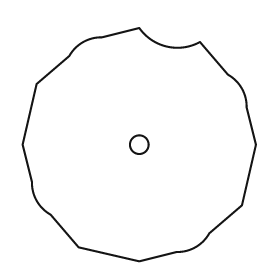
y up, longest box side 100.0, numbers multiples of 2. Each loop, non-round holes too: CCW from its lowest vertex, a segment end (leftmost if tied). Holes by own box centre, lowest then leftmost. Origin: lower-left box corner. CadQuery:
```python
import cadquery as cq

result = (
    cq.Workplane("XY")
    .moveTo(50.0, 0.0)
    .lineTo(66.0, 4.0)
    .threePointArc((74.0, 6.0), (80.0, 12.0))
    .lineTo(94.0, 24.0)
    .lineTo(100.0, 50.0)
    .lineTo(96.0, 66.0)
    .threePointArc((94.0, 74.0), (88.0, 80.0))
    .lineTo(76.0, 94.0)
    .threePointArc((62.0, 92.0), (50.0, 100.0))
    .lineTo(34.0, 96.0)
    .threePointArc((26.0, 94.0), (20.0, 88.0))
    .lineTo(6.0, 76.0)
    .lineTo(0.0, 50.0)
    .lineTo(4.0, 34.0)
    .threePointArc((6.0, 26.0), (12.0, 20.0))
    .lineTo(24.0, 6.0)
    .close()
    .moveTo(50.0, 50.0)
    .circle(4.0)
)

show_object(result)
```